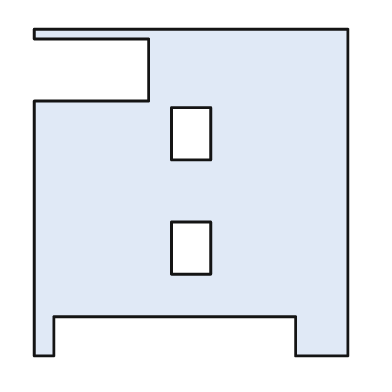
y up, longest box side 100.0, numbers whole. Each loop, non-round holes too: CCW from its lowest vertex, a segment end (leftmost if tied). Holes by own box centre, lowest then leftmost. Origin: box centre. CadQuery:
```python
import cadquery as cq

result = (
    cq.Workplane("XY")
    .moveTo(-48.0, -50.0)
    .lineTo(-42.0, -50.0)
    .lineTo(-42.0, -38.0)
    .lineTo(32.0, -38.0)
    .lineTo(32.0, -50.0)
    .lineTo(48.0, -50.0)
    .lineTo(48.0, 50.0)
    .lineTo(-48.0, 50.0)
    .lineTo(-48.0, 47.0)
    .lineTo(-13.0, 47.0)
    .lineTo(-13.0, 28.0)
    .lineTo(-48.0, 28.0)
    .close()
    .moveTo(-6.0, -25.0)
    .lineTo(6.0, -25.0)
    .lineTo(6.0, -9.0)
    .lineTo(-6.0, -9.0)
    .close()
    .moveTo(-6.0, 10.0)
    .lineTo(6.0, 10.0)
    .lineTo(6.0, 26.0)
    .lineTo(-6.0, 26.0)
    .close()
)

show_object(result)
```